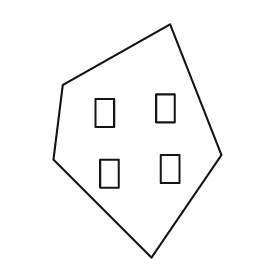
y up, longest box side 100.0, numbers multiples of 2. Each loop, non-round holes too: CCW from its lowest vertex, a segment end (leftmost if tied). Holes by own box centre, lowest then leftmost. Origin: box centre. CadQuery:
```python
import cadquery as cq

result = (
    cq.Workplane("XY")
    .moveTo(6.0, -50.0)
    .lineTo(36.0, -6.0)
    .lineTo(14.0, 50.0)
    .lineTo(-32.0, 24.0)
    .lineTo(-36.0, -8.0)
    .close()
    .moveTo(-16.0, -20.0)
    .lineTo(-8.0, -20.0)
    .lineTo(-8.0, -8.0)
    .lineTo(-16.0, -8.0)
    .close()
    .moveTo(10.0, -18.0)
    .lineTo(18.0, -18.0)
    .lineTo(18.0, -6.0)
    .lineTo(10.0, -6.0)
    .close()
    .moveTo(-18.0, 6.0)
    .lineTo(-10.0, 6.0)
    .lineTo(-10.0, 18.0)
    .lineTo(-18.0, 18.0)
    .close()
    .moveTo(8.0, 8.0)
    .lineTo(16.0, 8.0)
    .lineTo(16.0, 20.0)
    .lineTo(8.0, 20.0)
    .close()
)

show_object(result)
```